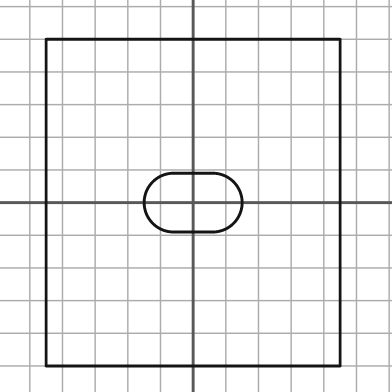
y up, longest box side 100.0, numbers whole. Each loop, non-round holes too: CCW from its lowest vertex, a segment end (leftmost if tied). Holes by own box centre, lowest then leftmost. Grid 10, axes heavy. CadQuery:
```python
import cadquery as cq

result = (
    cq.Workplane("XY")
    .moveTo(-45.0, -50.0)
    .lineTo(45.0, -50.0)
    .lineTo(45.0, 50.0)
    .lineTo(-45.0, 50.0)
    .close()
    .moveTo(-6.0, -9.0)
    .lineTo(6.0, -9.0)
    .threePointArc((15.0, 0.0), (6.0, 9.0))
    .lineTo(-6.0, 9.0)
    .threePointArc((-15.0, 0.0), (-6.0, -9.0))
    .close()
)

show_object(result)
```